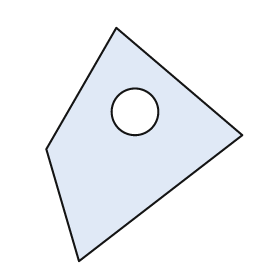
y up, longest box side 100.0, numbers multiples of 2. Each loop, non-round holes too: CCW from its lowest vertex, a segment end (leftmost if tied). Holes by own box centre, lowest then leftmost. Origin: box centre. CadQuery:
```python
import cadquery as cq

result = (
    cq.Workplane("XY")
    .moveTo(-28.0, -50.0)
    .lineTo(42.0, 4.0)
    .lineTo(-12.0, 50.0)
    .lineTo(-42.0, -2.0)
    .close()
    .moveTo(-4.0, 14.0)
    .circle(10.0)
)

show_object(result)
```